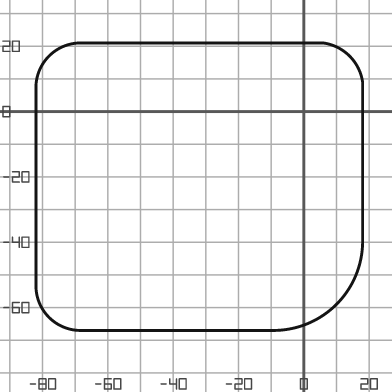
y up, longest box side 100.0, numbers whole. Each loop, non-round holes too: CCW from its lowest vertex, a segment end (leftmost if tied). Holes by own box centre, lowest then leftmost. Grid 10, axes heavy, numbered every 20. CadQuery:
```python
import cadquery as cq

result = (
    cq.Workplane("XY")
    .moveTo(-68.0, -67.0)
    .lineTo(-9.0, -67.0)
    .threePointArc((10.0, -59.0), (18.0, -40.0))
    .lineTo(18.0, 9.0)
    .threePointArc((14.0, 17.0), (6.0, 21.0))
    .lineTo(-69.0, 21.0)
    .threePointArc((-78.0, 17.0), (-82.0, 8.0))
    .lineTo(-82.0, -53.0)
    .threePointArc((-78.0, -63.0), (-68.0, -67.0))
    .close()
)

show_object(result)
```